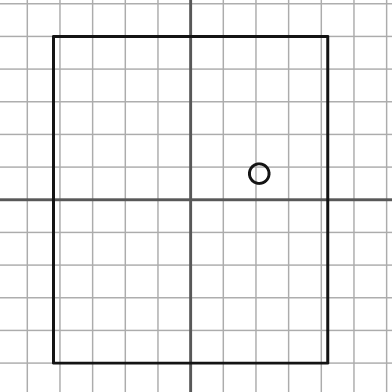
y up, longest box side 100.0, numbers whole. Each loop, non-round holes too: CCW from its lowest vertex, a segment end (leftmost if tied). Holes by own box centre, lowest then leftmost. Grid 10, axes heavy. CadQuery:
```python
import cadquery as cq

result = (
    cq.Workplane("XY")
    .moveTo(-42.0, -50.0)
    .lineTo(42.0, -50.0)
    .lineTo(42.0, 50.0)
    .lineTo(-42.0, 50.0)
    .close()
    .moveTo(21.0, 8.0)
    .circle(3.0)
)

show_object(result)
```